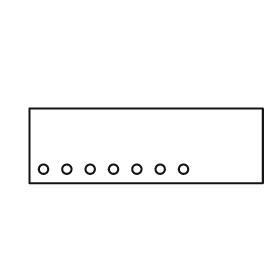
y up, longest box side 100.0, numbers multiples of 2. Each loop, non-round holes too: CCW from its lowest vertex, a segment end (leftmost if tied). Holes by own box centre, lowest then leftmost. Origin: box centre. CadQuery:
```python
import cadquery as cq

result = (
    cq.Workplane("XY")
    .moveTo(-50.0, -16.0)
    .lineTo(50.0, -16.0)
    .lineTo(50.0, 16.0)
    .lineTo(-50.0, 16.0)
    .close()
    .moveTo(-44.0, -10.0)
    .circle(2.0)
    .moveTo(-34.0, -10.0)
    .circle(2.0)
    .moveTo(-24.0, -10.0)
    .circle(2.0)
    .moveTo(-14.0, -10.0)
    .circle(2.0)
    .moveTo(-4.0, -10.0)
    .circle(2.0)
    .moveTo(6.0, -10.0)
    .circle(2.0)
    .moveTo(16.0, -10.0)
    .circle(2.0)
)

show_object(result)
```